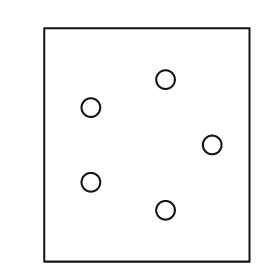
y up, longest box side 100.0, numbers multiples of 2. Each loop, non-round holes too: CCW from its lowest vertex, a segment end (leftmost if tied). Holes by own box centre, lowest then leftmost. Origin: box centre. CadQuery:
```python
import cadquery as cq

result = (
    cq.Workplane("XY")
    .moveTo(-44.0, -50.0)
    .lineTo(44.0, -50.0)
    .lineTo(44.0, 50.0)
    .lineTo(-44.0, 50.0)
    .close()
    .moveTo(8.0, -28.0)
    .circle(4.0)
    .moveTo(-24.0, -16.0)
    .circle(4.0)
    .moveTo(28.0, 0.0)
    .circle(4.0)
    .moveTo(-24.0, 16.0)
    .circle(4.0)
    .moveTo(8.0, 28.0)
    .circle(4.0)
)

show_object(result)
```